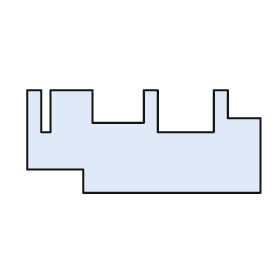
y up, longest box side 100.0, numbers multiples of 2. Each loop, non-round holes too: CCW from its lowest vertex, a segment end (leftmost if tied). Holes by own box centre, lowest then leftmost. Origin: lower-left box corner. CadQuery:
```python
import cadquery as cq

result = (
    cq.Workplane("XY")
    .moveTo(24.0, 0.0)
    .lineTo(100.0, 0.0)
    .lineTo(100.0, 32.0)
    .lineTo(86.0, 32.0)
    .lineTo(86.0, 44.0)
    .lineTo(80.0, 44.0)
    .lineTo(80.0, 26.0)
    .lineTo(56.0, 26.0)
    .lineTo(56.0, 44.0)
    .lineTo(50.0, 44.0)
    .lineTo(50.0, 30.0)
    .lineTo(28.0, 30.0)
    .lineTo(28.0, 44.0)
    .lineTo(10.0, 44.0)
    .lineTo(10.0, 26.0)
    .lineTo(6.0, 26.0)
    .lineTo(6.0, 44.0)
    .lineTo(0.0, 44.0)
    .lineTo(0.0, 10.0)
    .lineTo(24.0, 10.0)
    .close()
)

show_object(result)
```